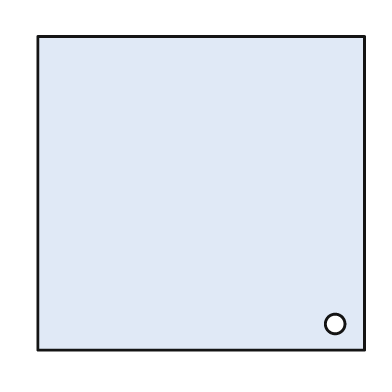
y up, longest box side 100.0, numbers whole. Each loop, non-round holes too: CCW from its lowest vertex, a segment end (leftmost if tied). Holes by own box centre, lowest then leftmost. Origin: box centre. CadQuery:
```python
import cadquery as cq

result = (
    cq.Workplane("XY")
    .moveTo(-50.0, -48.0)
    .lineTo(50.0, -48.0)
    .lineTo(50.0, 48.0)
    .lineTo(-50.0, 48.0)
    .close()
    .moveTo(41.0, -40.0)
    .circle(3.0)
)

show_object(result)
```